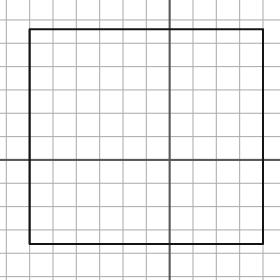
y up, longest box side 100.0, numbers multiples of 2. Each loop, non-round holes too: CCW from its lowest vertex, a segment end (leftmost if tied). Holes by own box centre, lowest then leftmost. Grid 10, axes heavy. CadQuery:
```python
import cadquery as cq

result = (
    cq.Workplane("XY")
    .moveTo(-60.0, -36.0)
    .lineTo(40.0, -36.0)
    .lineTo(40.0, 56.0)
    .lineTo(-60.0, 56.0)
    .close()
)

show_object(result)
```